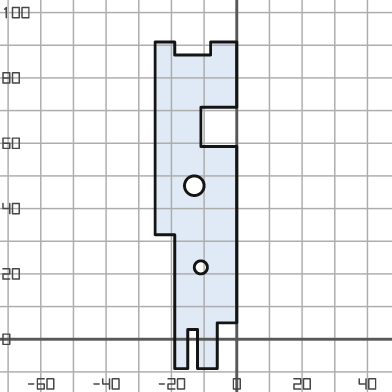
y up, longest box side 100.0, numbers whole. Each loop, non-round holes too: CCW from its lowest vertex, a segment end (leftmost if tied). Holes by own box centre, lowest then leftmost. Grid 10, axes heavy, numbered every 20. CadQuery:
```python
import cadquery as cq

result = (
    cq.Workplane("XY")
    .moveTo(-19.0, -9.0)
    .lineTo(-15.0, -9.0)
    .lineTo(-15.0, 3.0)
    .lineTo(-12.0, 3.0)
    .lineTo(-12.0, -9.0)
    .lineTo(-6.0, -9.0)
    .lineTo(-6.0, 5.0)
    .lineTo(0.0, 5.0)
    .lineTo(0.0, 59.0)
    .lineTo(-11.0, 59.0)
    .lineTo(-11.0, 71.0)
    .lineTo(0.0, 71.0)
    .lineTo(0.0, 91.0)
    .lineTo(-8.0, 91.0)
    .lineTo(-8.0, 87.0)
    .lineTo(-19.0, 87.0)
    .lineTo(-19.0, 91.0)
    .lineTo(-25.0, 91.0)
    .lineTo(-25.0, 32.0)
    .lineTo(-19.0, 32.0)
    .close()
    .moveTo(-11.0, 22.0)
    .circle(2.0)
    .moveTo(-13.0, 47.0)
    .circle(3.0)
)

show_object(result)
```